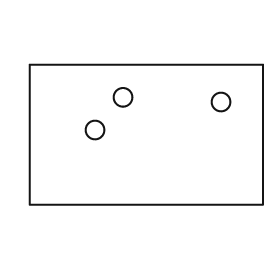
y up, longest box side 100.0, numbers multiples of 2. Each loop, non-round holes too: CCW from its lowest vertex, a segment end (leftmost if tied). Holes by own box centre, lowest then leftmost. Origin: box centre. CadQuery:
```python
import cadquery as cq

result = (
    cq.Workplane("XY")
    .moveTo(-50.0, -30.0)
    .lineTo(50.0, -30.0)
    .lineTo(50.0, 30.0)
    .lineTo(-50.0, 30.0)
    .close()
    .moveTo(-22.0, 2.0)
    .circle(4.0)
    .moveTo(32.0, 14.0)
    .circle(4.0)
    .moveTo(-10.0, 16.0)
    .circle(4.0)
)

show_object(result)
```